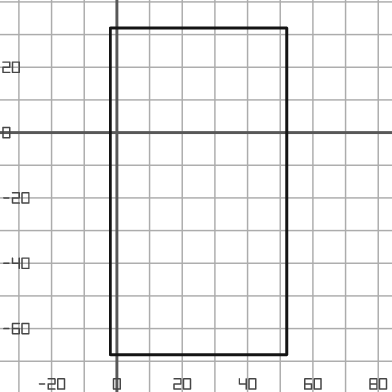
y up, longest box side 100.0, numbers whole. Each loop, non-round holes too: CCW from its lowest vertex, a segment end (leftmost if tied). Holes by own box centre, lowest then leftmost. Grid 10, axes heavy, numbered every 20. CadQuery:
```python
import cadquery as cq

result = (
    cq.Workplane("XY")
    .moveTo(-2.0, -68.0)
    .lineTo(52.0, -68.0)
    .lineTo(52.0, 32.0)
    .lineTo(-2.0, 32.0)
    .close()
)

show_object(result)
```